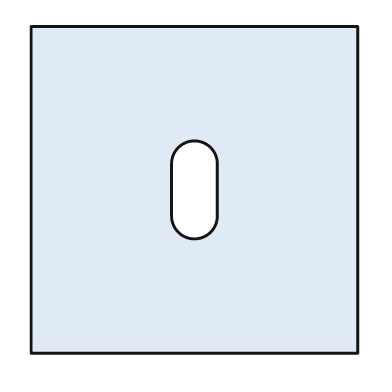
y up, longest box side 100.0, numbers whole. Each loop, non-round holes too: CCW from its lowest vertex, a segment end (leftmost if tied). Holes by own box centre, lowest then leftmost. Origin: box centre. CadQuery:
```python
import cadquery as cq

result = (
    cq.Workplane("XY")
    .moveTo(-50.0, -50.0)
    .lineTo(50.0, -50.0)
    .lineTo(50.0, 50.0)
    .lineTo(-50.0, 50.0)
    .close()
    .moveTo(-7.0, -8.0)
    .threePointArc((0.0, -15.0), (7.0, -8.0))
    .lineTo(7.0, 8.0)
    .threePointArc((0.0, 15.0), (-7.0, 8.0))
    .close()
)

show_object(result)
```